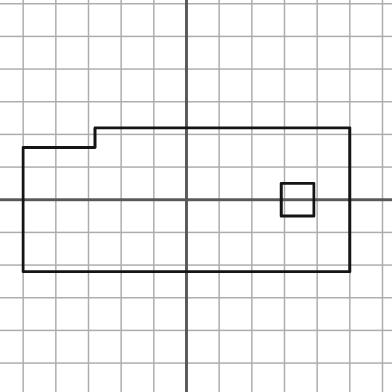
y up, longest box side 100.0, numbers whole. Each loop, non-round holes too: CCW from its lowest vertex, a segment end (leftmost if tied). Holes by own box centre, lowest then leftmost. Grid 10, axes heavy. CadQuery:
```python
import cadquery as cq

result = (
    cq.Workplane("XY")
    .moveTo(-50.0, -22.0)
    .lineTo(50.0, -22.0)
    .lineTo(50.0, 22.0)
    .lineTo(-28.0, 22.0)
    .lineTo(-28.0, 16.0)
    .lineTo(-50.0, 16.0)
    .close()
    .moveTo(29.0, -5.0)
    .lineTo(39.0, -5.0)
    .lineTo(39.0, 5.0)
    .lineTo(29.0, 5.0)
    .close()
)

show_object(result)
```